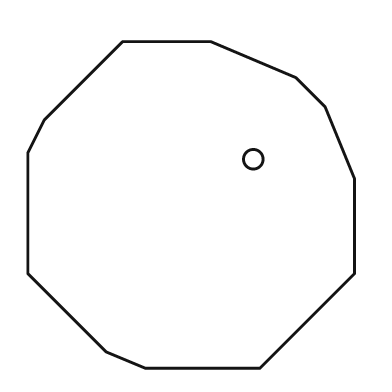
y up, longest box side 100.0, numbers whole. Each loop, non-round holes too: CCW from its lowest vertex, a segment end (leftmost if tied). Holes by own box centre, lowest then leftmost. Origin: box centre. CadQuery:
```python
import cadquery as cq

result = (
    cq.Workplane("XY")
    .moveTo(-14.0, -50.0)
    .lineTo(21.0, -50.0)
    .lineTo(50.0, -21.0)
    .lineTo(50.0, 8.0)
    .lineTo(41.0, 30.0)
    .lineTo(32.0, 39.0)
    .lineTo(6.0, 50.0)
    .lineTo(-21.0, 50.0)
    .lineTo(-45.0, 26.0)
    .lineTo(-50.0, 16.0)
    .lineTo(-50.0, -21.0)
    .lineTo(-26.0, -45.0)
    .close()
    .moveTo(19.0, 14.0)
    .circle(3.0)
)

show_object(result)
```